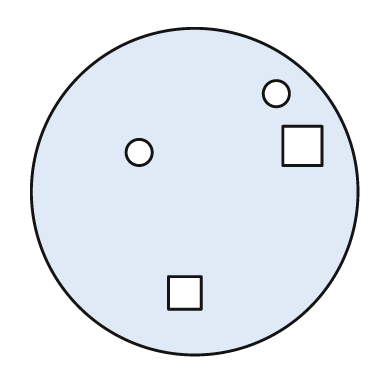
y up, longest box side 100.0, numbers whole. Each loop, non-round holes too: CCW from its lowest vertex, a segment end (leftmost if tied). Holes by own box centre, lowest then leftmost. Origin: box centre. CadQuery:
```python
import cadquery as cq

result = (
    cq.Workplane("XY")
    .moveTo(0.0, 0.0)
    .circle(50.0)
    .moveTo(-8.0, -36.0)
    .lineTo(2.0, -36.0)
    .lineTo(2.0, -26.0)
    .lineTo(-8.0, -26.0)
    .close()
    .moveTo(-17.0, 12.0)
    .circle(4.0)
    .moveTo(27.0, 8.0)
    .lineTo(39.0, 8.0)
    .lineTo(39.0, 20.0)
    .lineTo(27.0, 20.0)
    .close()
    .moveTo(25.0, 30.0)
    .circle(4.0)
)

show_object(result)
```